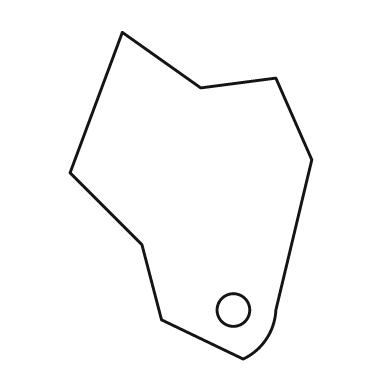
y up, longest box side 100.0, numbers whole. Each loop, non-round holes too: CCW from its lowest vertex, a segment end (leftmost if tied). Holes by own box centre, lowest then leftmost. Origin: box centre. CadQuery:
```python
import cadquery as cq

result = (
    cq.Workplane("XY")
    .moveTo(16.0, -50.0)
    .threePointArc((23.0, -44.0), (26.0, -35.0))
    .lineTo(37.0, 11.0)
    .lineTo(26.0, 36.0)
    .lineTo(3.0, 33.0)
    .lineTo(-21.0, 50.0)
    .lineTo(-37.0, 7.0)
    .lineTo(-15.0, -15.0)
    .lineTo(-9.0, -38.0)
    .close()
    .moveTo(13.0, -35.0)
    .circle(5.0)
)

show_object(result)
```